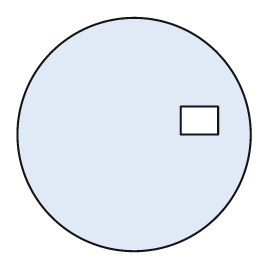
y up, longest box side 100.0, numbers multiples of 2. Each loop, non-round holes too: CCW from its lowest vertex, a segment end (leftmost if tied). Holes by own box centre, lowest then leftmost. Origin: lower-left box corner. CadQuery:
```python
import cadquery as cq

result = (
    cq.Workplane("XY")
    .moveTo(50.0, 50.0)
    .circle(50.0)
    .moveTo(70.0, 50.0)
    .lineTo(86.0, 50.0)
    .lineTo(86.0, 62.0)
    .lineTo(70.0, 62.0)
    .close()
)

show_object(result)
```